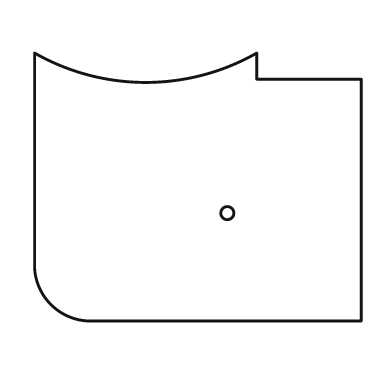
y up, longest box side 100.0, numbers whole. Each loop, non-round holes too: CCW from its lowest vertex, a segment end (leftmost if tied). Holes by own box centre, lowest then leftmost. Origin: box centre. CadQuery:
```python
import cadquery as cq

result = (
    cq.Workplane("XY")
    .moveTo(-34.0, -41.0)
    .lineTo(50.0, -41.0)
    .lineTo(50.0, 33.0)
    .lineTo(18.0, 33.0)
    .lineTo(18.0, 41.0)
    .threePointArc((-16.0, 32.0), (-50.0, 41.0))
    .lineTo(-50.0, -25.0)
    .threePointArc((-45.0, -36.0), (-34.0, -41.0))
    .close()
    .moveTo(9.0, -8.0)
    .circle(2.0)
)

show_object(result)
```